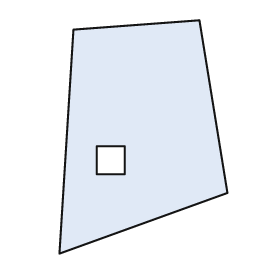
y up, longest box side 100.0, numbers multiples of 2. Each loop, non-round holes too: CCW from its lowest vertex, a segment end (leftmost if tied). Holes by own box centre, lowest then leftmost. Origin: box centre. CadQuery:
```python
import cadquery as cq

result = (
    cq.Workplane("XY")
    .moveTo(-36.0, -50.0)
    .lineTo(36.0, -24.0)
    .lineTo(24.0, 50.0)
    .lineTo(-30.0, 46.0)
    .close()
    .moveTo(-20.0, -16.0)
    .lineTo(-8.0, -16.0)
    .lineTo(-8.0, -4.0)
    .lineTo(-20.0, -4.0)
    .close()
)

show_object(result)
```